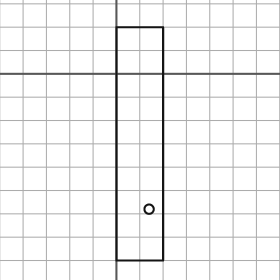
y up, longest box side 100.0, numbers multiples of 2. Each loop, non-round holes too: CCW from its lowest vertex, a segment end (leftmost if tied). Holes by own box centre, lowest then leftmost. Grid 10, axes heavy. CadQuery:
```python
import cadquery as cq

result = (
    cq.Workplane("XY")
    .moveTo(0.0, -80.0)
    .lineTo(20.0, -80.0)
    .lineTo(20.0, 20.0)
    .lineTo(0.0, 20.0)
    .close()
    .moveTo(14.0, -58.0)
    .circle(2.0)
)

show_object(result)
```